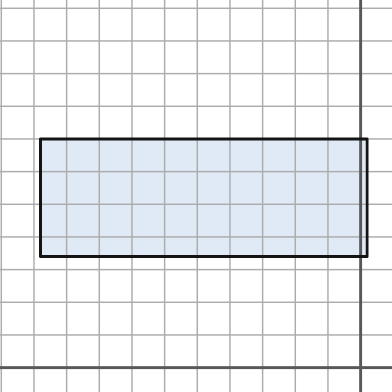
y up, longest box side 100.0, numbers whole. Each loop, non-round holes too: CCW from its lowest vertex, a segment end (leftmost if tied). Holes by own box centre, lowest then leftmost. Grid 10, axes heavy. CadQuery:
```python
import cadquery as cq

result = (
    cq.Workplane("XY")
    .moveTo(-98.0, 34.0)
    .lineTo(2.0, 34.0)
    .lineTo(2.0, 70.0)
    .lineTo(-98.0, 70.0)
    .close()
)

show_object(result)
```